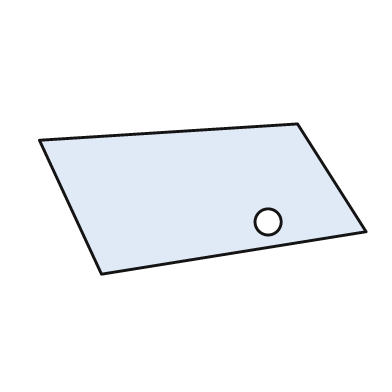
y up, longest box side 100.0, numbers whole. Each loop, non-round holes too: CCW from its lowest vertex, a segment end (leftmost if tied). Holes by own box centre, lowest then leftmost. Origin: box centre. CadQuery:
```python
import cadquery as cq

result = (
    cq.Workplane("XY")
    .moveTo(-31.0, -23.0)
    .lineTo(50.0, -10.0)
    .lineTo(29.0, 23.0)
    .lineTo(-50.0, 18.0)
    .close()
    .moveTo(20.0, -7.0)
    .circle(4.0)
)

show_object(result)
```